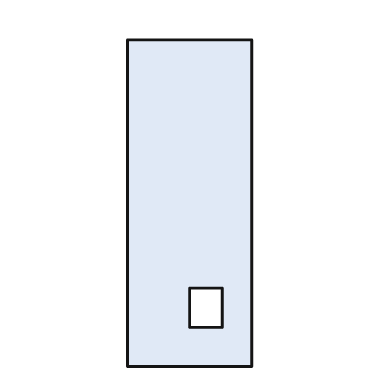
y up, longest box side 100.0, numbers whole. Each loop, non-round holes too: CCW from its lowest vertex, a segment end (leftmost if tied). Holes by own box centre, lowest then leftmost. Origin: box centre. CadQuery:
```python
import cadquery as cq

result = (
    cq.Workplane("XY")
    .moveTo(-19.0, -50.0)
    .lineTo(19.0, -50.0)
    .lineTo(19.0, 50.0)
    .lineTo(-19.0, 50.0)
    .close()
    .moveTo(0.0, -38.0)
    .lineTo(10.0, -38.0)
    .lineTo(10.0, -26.0)
    .lineTo(0.0, -26.0)
    .close()
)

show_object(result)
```